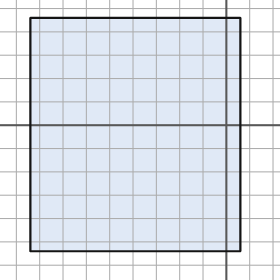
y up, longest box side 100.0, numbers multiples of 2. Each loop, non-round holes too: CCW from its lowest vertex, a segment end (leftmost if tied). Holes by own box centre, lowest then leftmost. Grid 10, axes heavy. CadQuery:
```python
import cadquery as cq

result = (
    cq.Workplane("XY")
    .moveTo(-84.0, -54.0)
    .lineTo(6.0, -54.0)
    .lineTo(6.0, 46.0)
    .lineTo(-84.0, 46.0)
    .close()
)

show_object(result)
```